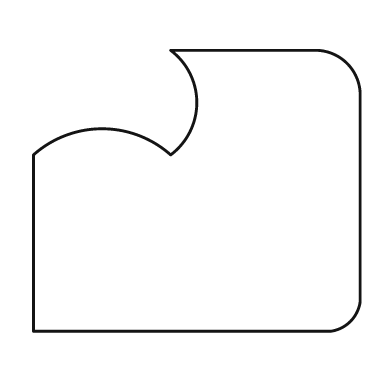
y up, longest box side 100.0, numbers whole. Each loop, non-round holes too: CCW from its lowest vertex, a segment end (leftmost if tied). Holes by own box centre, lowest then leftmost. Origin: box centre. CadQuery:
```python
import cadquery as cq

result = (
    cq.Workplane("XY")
    .moveTo(-50.0, -43.0)
    .lineTo(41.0, -43.0)
    .threePointArc((47.0, -40.0), (50.0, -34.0))
    .lineTo(50.0, 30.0)
    .threePointArc((46.0, 39.0), (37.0, 43.0))
    .lineTo(-8.0, 43.0)
    .threePointArc((0.0, 27.0), (-8.0, 11.0))
    .threePointArc((-29.0, 19.0), (-50.0, 11.0))
    .close()
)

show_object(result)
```